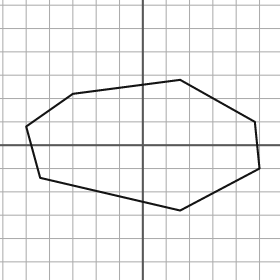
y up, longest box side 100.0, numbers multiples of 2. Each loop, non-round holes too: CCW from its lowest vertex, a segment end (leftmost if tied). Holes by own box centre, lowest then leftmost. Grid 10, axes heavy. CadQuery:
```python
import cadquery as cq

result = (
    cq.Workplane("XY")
    .moveTo(16.0, -28.0)
    .lineTo(50.0, -10.0)
    .lineTo(48.0, 10.0)
    .lineTo(16.0, 28.0)
    .lineTo(-30.0, 22.0)
    .lineTo(-50.0, 8.0)
    .lineTo(-44.0, -14.0)
    .close()
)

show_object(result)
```